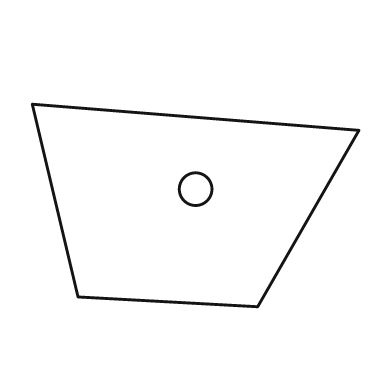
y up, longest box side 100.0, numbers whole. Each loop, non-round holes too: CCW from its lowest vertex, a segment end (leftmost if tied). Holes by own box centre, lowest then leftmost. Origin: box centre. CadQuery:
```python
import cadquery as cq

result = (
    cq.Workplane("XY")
    .moveTo(19.0, -31.0)
    .lineTo(50.0, 23.0)
    .lineTo(-50.0, 31.0)
    .lineTo(-36.0, -28.0)
    .close()
    .moveTo(0.0, 5.0)
    .circle(5.0)
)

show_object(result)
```